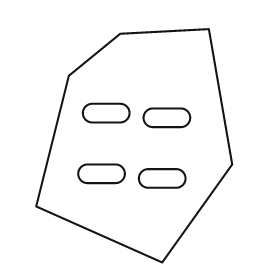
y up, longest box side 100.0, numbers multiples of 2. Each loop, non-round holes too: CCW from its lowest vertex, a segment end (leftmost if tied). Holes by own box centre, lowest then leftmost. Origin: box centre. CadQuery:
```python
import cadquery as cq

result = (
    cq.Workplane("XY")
    .moveTo(12.0, -50.0)
    .lineTo(42.0, -8.0)
    .lineTo(32.0, 50.0)
    .lineTo(-6.0, 48.0)
    .lineTo(-28.0, 30.0)
    .lineTo(-42.0, -26.0)
    .close()
    .moveTo(6.0, -18.0)
    .lineTo(18.0, -18.0)
    .threePointArc((22.0, -14.0), (18.0, -10.0))
    .lineTo(6.0, -10.0)
    .threePointArc((2.0, -14.0), (6.0, -18.0))
    .close()
    .moveTo(-20.0, -16.0)
    .lineTo(-8.0, -16.0)
    .threePointArc((-4.0, -12.0), (-8.0, -8.0))
    .lineTo(-20.0, -8.0)
    .threePointArc((-24.0, -12.0), (-20.0, -16.0))
    .close()
    .moveTo(8.0, 8.0)
    .lineTo(20.0, 8.0)
    .threePointArc((24.0, 12.0), (20.0, 16.0))
    .lineTo(8.0, 16.0)
    .threePointArc((4.0, 12.0), (8.0, 8.0))
    .close()
    .moveTo(-18.0, 10.0)
    .lineTo(-6.0, 10.0)
    .threePointArc((-2.0, 14.0), (-6.0, 18.0))
    .lineTo(-18.0, 18.0)
    .threePointArc((-22.0, 14.0), (-18.0, 10.0))
    .close()
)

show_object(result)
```